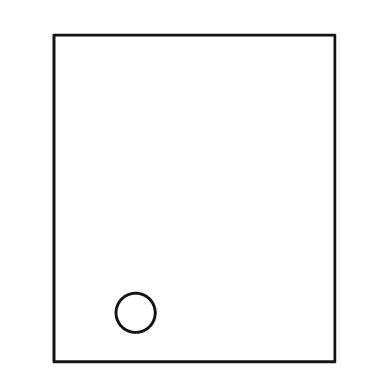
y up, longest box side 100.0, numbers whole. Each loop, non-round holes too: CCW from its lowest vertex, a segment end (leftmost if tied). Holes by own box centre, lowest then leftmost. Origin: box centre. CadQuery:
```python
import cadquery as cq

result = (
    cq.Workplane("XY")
    .moveTo(-43.0, -50.0)
    .lineTo(43.0, -50.0)
    .lineTo(43.0, 50.0)
    .lineTo(-43.0, 50.0)
    .close()
    .moveTo(-18.0, -35.0)
    .circle(6.0)
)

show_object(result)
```